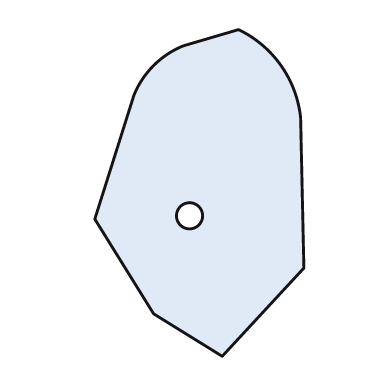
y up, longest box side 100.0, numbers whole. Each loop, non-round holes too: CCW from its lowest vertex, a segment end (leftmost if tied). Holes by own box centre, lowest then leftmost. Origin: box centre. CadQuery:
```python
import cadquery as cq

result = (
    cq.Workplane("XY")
    .moveTo(7.0, -50.0)
    .lineTo(32.0, -23.0)
    .lineTo(31.0, 23.0)
    .threePointArc((25.0, 39.0), (12.0, 50.0))
    .lineTo(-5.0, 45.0)
    .threePointArc((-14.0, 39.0), (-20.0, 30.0))
    .lineTo(-32.0, -8.0)
    .lineTo(-14.0, -37.0)
    .close()
    .moveTo(-3.0, -7.0)
    .circle(4.0)
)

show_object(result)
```